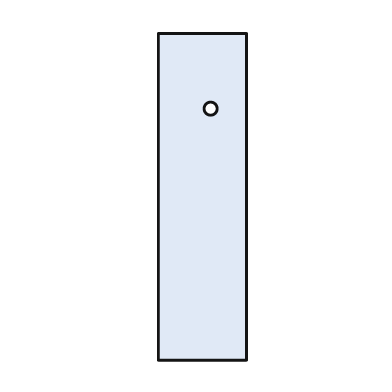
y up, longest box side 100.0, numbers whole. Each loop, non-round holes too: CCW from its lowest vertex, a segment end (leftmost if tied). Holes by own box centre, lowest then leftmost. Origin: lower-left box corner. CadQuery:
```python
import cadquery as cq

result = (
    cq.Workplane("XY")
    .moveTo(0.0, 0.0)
    .lineTo(27.0, 0.0)
    .lineTo(27.0, 100.0)
    .lineTo(0.0, 100.0)
    .close()
    .moveTo(16.0, 77.0)
    .circle(2.0)
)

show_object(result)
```